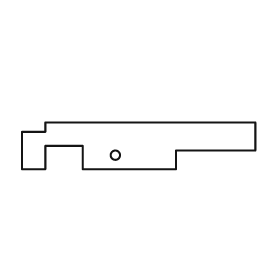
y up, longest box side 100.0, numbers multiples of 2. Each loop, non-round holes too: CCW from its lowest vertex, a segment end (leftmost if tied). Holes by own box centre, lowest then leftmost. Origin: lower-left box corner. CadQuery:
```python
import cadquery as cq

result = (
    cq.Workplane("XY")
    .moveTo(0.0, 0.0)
    .lineTo(10.0, 0.0)
    .lineTo(10.0, 10.0)
    .lineTo(26.0, 10.0)
    .lineTo(26.0, 0.0)
    .lineTo(66.0, 0.0)
    .lineTo(66.0, 8.0)
    .lineTo(100.0, 8.0)
    .lineTo(100.0, 20.0)
    .lineTo(10.0, 20.0)
    .lineTo(10.0, 16.0)
    .lineTo(0.0, 16.0)
    .close()
    .moveTo(40.0, 6.0)
    .circle(2.0)
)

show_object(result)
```